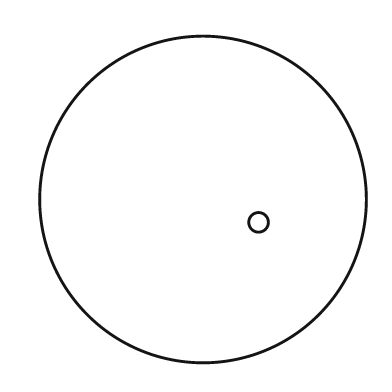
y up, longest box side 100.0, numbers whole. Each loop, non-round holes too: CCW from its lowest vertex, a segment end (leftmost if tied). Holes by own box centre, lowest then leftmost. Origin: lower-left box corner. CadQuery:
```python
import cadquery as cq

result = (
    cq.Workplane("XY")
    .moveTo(50.0, 50.0)
    .circle(50.0)
    .moveTo(67.0, 43.0)
    .circle(3.0)
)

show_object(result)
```